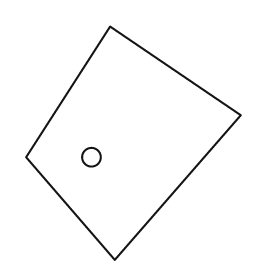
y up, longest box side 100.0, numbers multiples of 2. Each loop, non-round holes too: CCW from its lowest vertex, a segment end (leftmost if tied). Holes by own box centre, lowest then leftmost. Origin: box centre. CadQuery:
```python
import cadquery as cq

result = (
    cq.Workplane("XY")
    .moveTo(-8.0, -50.0)
    .lineTo(46.0, 12.0)
    .lineTo(-10.0, 50.0)
    .lineTo(-46.0, -6.0)
    .close()
    .moveTo(-18.0, -6.0)
    .circle(4.0)
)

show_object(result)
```